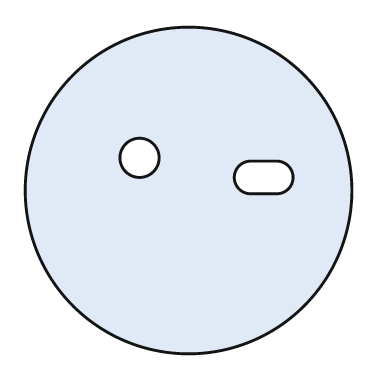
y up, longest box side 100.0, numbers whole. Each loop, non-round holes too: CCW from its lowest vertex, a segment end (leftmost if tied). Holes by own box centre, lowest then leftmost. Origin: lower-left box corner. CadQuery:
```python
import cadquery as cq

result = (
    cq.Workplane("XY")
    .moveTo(50.0, 50.0)
    .circle(50.0)
    .moveTo(69.0, 49.0)
    .lineTo(77.0, 49.0)
    .threePointArc((82.0, 54.0), (77.0, 59.0))
    .lineTo(69.0, 59.0)
    .threePointArc((64.0, 54.0), (69.0, 49.0))
    .close()
    .moveTo(35.0, 60.0)
    .circle(6.0)
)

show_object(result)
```